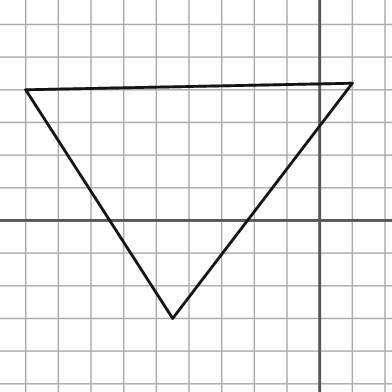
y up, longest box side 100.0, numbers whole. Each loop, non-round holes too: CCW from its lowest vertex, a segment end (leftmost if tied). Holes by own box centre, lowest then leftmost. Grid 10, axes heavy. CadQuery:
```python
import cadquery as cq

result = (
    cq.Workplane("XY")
    .moveTo(-45.0, -30.0)
    .lineTo(10.0, 42.0)
    .lineTo(-90.0, 40.0)
    .close()
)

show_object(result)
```